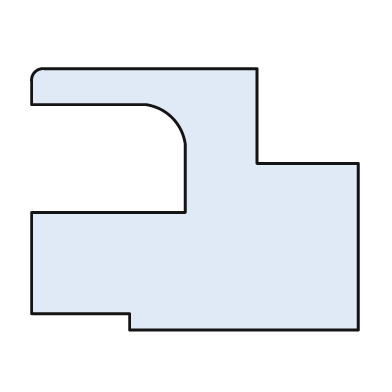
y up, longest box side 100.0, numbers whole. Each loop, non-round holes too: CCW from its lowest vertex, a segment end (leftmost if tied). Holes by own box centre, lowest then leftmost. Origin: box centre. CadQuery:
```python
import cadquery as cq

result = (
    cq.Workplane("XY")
    .moveTo(-20.0, -40.0)
    .lineTo(50.0, -40.0)
    .lineTo(50.0, 11.0)
    .lineTo(19.0, 11.0)
    .lineTo(19.0, 40.0)
    .lineTo(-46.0, 40.0)
    .threePointArc((-49.0, 39.0), (-50.0, 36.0))
    .lineTo(-50.0, 29.0)
    .lineTo(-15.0, 29.0)
    .threePointArc((-7.0, 25.0), (-3.0, 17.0))
    .lineTo(-3.0, -4.0)
    .lineTo(-50.0, -4.0)
    .lineTo(-50.0, -35.0)
    .lineTo(-20.0, -35.0)
    .close()
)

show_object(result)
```